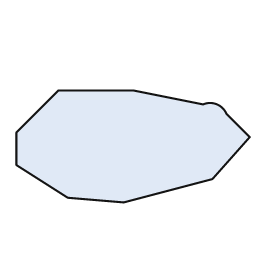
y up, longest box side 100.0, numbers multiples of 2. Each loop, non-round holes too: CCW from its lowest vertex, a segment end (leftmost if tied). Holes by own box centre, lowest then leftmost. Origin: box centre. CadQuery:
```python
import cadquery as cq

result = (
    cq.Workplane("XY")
    .moveTo(-4.0, -24.0)
    .lineTo(34.0, -14.0)
    .lineTo(50.0, 4.0)
    .lineTo(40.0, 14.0)
    .threePointArc((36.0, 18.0), (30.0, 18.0))
    .lineTo(0.0, 24.0)
    .lineTo(-32.0, 24.0)
    .lineTo(-50.0, 6.0)
    .lineTo(-50.0, -8.0)
    .lineTo(-28.0, -22.0)
    .close()
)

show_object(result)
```